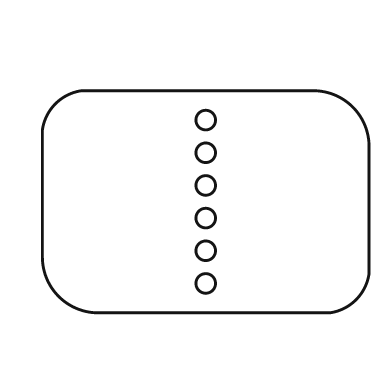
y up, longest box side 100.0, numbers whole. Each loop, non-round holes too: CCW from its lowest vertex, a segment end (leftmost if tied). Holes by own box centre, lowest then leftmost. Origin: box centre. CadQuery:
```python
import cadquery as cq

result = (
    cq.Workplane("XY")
    .moveTo(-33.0, -34.0)
    .lineTo(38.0, -34.0)
    .threePointArc((46.0, -30.0), (50.0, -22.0))
    .lineTo(50.0, 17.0)
    .threePointArc((45.0, 29.0), (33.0, 34.0))
    .lineTo(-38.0, 34.0)
    .threePointArc((-46.0, 30.0), (-50.0, 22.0))
    .lineTo(-50.0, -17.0)
    .threePointArc((-45.0, -29.0), (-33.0, -34.0))
    .close()
    .moveTo(0.0, -25.0)
    .circle(3.0)
    .moveTo(0.0, -15.0)
    .circle(3.0)
    .moveTo(0.0, -5.0)
    .circle(3.0)
    .moveTo(0.0, 5.0)
    .circle(3.0)
    .moveTo(0.0, 15.0)
    .circle(3.0)
    .moveTo(0.0, 25.0)
    .circle(3.0)
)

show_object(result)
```